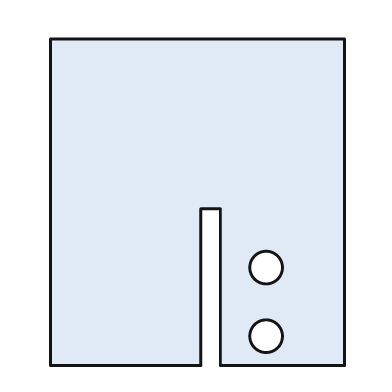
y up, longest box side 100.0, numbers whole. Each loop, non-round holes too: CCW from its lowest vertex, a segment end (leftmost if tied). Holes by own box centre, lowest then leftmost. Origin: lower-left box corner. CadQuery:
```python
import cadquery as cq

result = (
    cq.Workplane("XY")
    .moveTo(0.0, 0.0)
    .lineTo(46.0, 0.0)
    .lineTo(46.0, 48.0)
    .lineTo(52.0, 48.0)
    .lineTo(52.0, 0.0)
    .lineTo(90.0, 0.0)
    .lineTo(90.0, 100.0)
    .lineTo(0.0, 100.0)
    .close()
    .moveTo(66.0, 9.0)
    .circle(5.0)
    .moveTo(66.0, 30.0)
    .circle(5.0)
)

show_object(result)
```